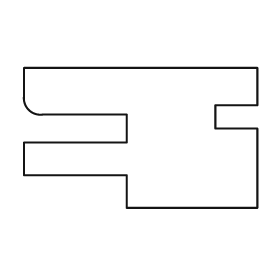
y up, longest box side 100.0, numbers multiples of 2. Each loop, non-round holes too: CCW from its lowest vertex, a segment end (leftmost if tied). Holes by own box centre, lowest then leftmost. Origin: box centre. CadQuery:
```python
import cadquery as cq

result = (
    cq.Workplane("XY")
    .moveTo(-6.0, -30.0)
    .lineTo(50.0, -30.0)
    .lineTo(50.0, 4.0)
    .lineTo(32.0, 4.0)
    .lineTo(32.0, 14.0)
    .lineTo(50.0, 14.0)
    .lineTo(50.0, 30.0)
    .lineTo(-50.0, 30.0)
    .lineTo(-50.0, 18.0)
    .threePointArc((-48.0, 12.0), (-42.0, 10.0))
    .lineTo(-6.0, 10.0)
    .lineTo(-6.0, -2.0)
    .lineTo(-50.0, -2.0)
    .lineTo(-50.0, -16.0)
    .lineTo(-6.0, -16.0)
    .close()
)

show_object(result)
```